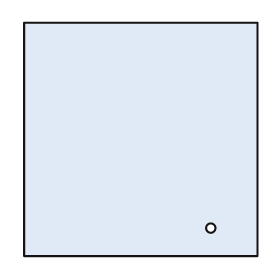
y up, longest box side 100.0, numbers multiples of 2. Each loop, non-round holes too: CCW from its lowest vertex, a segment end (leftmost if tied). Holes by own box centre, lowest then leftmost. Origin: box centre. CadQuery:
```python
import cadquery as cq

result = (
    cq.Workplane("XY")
    .moveTo(-50.0, -50.0)
    .lineTo(50.0, -50.0)
    .lineTo(50.0, 50.0)
    .lineTo(-50.0, 50.0)
    .close()
    .moveTo(30.0, -38.0)
    .circle(2.0)
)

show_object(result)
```